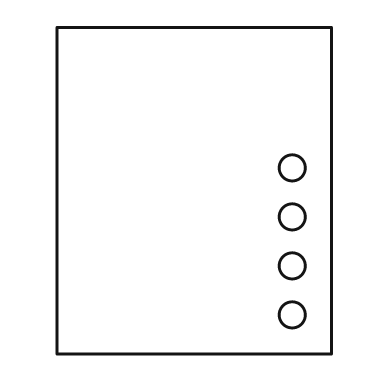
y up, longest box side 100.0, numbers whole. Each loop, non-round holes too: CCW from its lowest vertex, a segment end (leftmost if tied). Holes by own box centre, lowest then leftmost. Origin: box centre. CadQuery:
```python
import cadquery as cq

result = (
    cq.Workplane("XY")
    .moveTo(-42.0, -50.0)
    .lineTo(42.0, -50.0)
    .lineTo(42.0, 50.0)
    .lineTo(-42.0, 50.0)
    .close()
    .moveTo(30.0, -38.0)
    .circle(4.0)
    .moveTo(30.0, -23.0)
    .circle(4.0)
    .moveTo(30.0, -8.0)
    .circle(4.0)
    .moveTo(30.0, 7.0)
    .circle(4.0)
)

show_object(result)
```